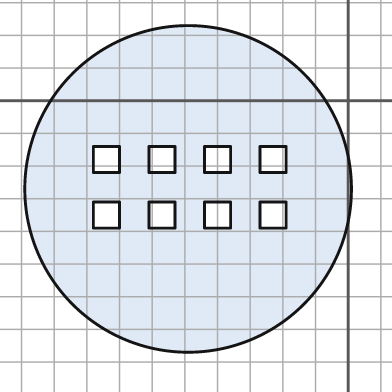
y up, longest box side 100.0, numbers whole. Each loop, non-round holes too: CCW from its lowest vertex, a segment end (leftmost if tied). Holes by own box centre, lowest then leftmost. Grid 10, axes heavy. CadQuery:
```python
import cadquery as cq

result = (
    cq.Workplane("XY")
    .moveTo(-49.0, -27.0)
    .circle(50.0)
    .moveTo(-78.0, -39.0)
    .lineTo(-70.0, -39.0)
    .lineTo(-70.0, -31.0)
    .lineTo(-78.0, -31.0)
    .close()
    .moveTo(-61.0, -39.0)
    .lineTo(-53.0, -39.0)
    .lineTo(-53.0, -31.0)
    .lineTo(-61.0, -31.0)
    .close()
    .moveTo(-44.0, -39.0)
    .lineTo(-36.0, -39.0)
    .lineTo(-36.0, -31.0)
    .lineTo(-44.0, -31.0)
    .close()
    .moveTo(-27.0, -39.0)
    .lineTo(-19.0, -39.0)
    .lineTo(-19.0, -31.0)
    .lineTo(-27.0, -31.0)
    .close()
    .moveTo(-78.0, -22.0)
    .lineTo(-70.0, -22.0)
    .lineTo(-70.0, -14.0)
    .lineTo(-78.0, -14.0)
    .close()
    .moveTo(-61.0, -22.0)
    .lineTo(-53.0, -22.0)
    .lineTo(-53.0, -14.0)
    .lineTo(-61.0, -14.0)
    .close()
    .moveTo(-44.0, -22.0)
    .lineTo(-36.0, -22.0)
    .lineTo(-36.0, -14.0)
    .lineTo(-44.0, -14.0)
    .close()
    .moveTo(-27.0, -22.0)
    .lineTo(-19.0, -22.0)
    .lineTo(-19.0, -14.0)
    .lineTo(-27.0, -14.0)
    .close()
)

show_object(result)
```